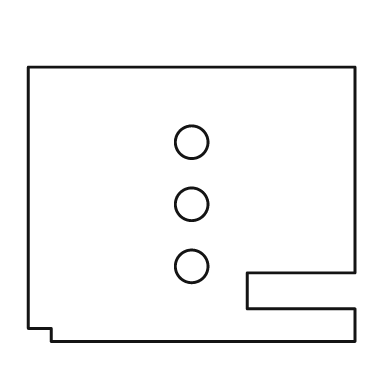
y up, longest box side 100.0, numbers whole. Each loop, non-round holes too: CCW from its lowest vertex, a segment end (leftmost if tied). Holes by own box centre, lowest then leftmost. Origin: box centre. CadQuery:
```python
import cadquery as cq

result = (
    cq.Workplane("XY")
    .moveTo(-43.0, -42.0)
    .lineTo(50.0, -42.0)
    .lineTo(50.0, -32.0)
    .lineTo(17.0, -32.0)
    .lineTo(17.0, -21.0)
    .lineTo(50.0, -21.0)
    .lineTo(50.0, 42.0)
    .lineTo(-50.0, 42.0)
    .lineTo(-50.0, -38.0)
    .lineTo(-43.0, -38.0)
    .close()
    .moveTo(0.0, -19.0)
    .circle(5.0)
    .moveTo(0.0, 0.0)
    .circle(5.0)
    .moveTo(0.0, 19.0)
    .circle(5.0)
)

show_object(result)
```